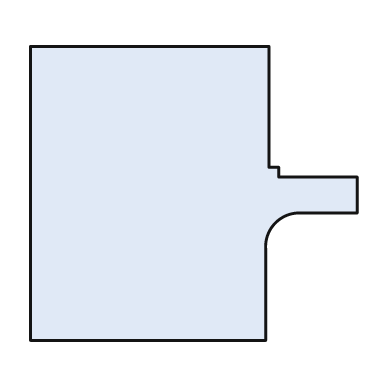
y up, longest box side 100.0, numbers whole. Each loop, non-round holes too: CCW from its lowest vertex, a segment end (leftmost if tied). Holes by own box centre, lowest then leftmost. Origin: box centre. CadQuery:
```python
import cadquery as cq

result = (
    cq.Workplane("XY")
    .moveTo(-50.0, -45.0)
    .lineTo(22.0, -45.0)
    .lineTo(22.0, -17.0)
    .threePointArc((25.0, -9.0), (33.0, -6.0))
    .lineTo(50.0, -6.0)
    .lineTo(50.0, 5.0)
    .lineTo(26.0, 5.0)
    .lineTo(26.0, 8.0)
    .lineTo(23.0, 8.0)
    .lineTo(23.0, 45.0)
    .lineTo(-50.0, 45.0)
    .close()
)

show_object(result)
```